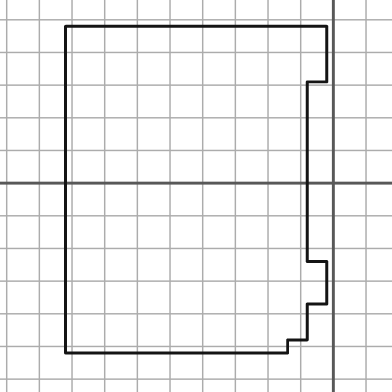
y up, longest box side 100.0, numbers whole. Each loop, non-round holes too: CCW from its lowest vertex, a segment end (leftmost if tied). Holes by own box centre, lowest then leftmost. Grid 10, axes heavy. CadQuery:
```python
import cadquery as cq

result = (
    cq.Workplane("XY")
    .moveTo(-82.0, -52.0)
    .lineTo(-14.0, -52.0)
    .lineTo(-14.0, -48.0)
    .lineTo(-8.0, -48.0)
    .lineTo(-8.0, -37.0)
    .lineTo(-2.0, -37.0)
    .lineTo(-2.0, -24.0)
    .lineTo(-8.0, -24.0)
    .lineTo(-8.0, 31.0)
    .lineTo(-2.0, 31.0)
    .lineTo(-2.0, 48.0)
    .lineTo(-82.0, 48.0)
    .close()
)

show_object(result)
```